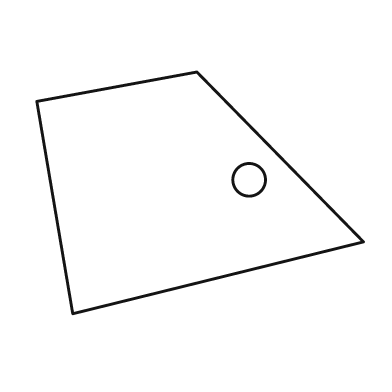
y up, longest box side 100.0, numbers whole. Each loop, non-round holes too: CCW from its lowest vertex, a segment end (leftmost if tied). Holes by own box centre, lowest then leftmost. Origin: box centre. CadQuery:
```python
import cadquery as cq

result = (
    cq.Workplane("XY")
    .moveTo(-39.0, -37.0)
    .lineTo(50.0, -15.0)
    .lineTo(-1.0, 37.0)
    .lineTo(-50.0, 28.0)
    .close()
    .moveTo(15.0, 4.0)
    .circle(5.0)
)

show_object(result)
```